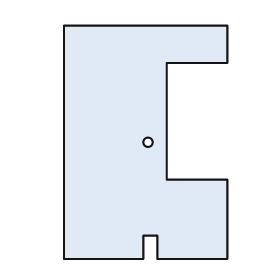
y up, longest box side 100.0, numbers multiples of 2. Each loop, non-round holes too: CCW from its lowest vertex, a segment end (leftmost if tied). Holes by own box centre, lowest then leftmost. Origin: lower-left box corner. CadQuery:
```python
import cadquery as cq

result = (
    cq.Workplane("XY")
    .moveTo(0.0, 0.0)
    .lineTo(34.0, 0.0)
    .lineTo(34.0, 10.0)
    .lineTo(40.0, 10.0)
    .lineTo(40.0, 0.0)
    .lineTo(70.0, 0.0)
    .lineTo(70.0, 34.0)
    .lineTo(44.0, 34.0)
    .lineTo(44.0, 84.0)
    .lineTo(70.0, 84.0)
    .lineTo(70.0, 100.0)
    .lineTo(0.0, 100.0)
    .close()
    .moveTo(36.0, 50.0)
    .circle(2.0)
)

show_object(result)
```